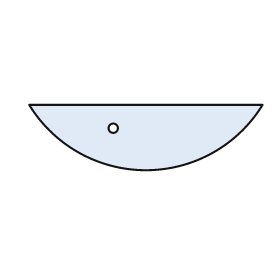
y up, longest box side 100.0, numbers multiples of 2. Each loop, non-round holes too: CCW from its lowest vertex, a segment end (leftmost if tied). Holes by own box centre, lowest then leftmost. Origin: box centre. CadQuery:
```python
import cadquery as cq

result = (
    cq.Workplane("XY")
    .moveTo(-50.0, 14.0)
    .threePointArc((0.0, -14.0), (50.0, 14.0))
    .close()
    .moveTo(-14.0, 4.0)
    .circle(2.0)
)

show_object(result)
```